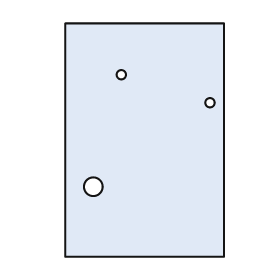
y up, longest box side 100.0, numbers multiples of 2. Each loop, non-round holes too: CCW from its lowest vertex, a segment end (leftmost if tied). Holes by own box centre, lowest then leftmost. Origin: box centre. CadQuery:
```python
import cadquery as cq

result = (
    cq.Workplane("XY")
    .moveTo(-34.0, -50.0)
    .lineTo(34.0, -50.0)
    .lineTo(34.0, 50.0)
    .lineTo(-34.0, 50.0)
    .close()
    .moveTo(-22.0, -20.0)
    .circle(4.0)
    .moveTo(28.0, 16.0)
    .circle(2.0)
    .moveTo(-10.0, 28.0)
    .circle(2.0)
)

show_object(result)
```